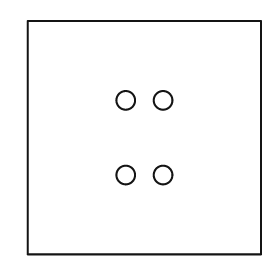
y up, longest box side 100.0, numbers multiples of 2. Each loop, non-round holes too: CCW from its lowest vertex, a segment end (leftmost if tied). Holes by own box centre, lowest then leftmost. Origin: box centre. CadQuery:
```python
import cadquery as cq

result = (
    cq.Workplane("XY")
    .moveTo(-50.0, -50.0)
    .lineTo(50.0, -50.0)
    .lineTo(50.0, 50.0)
    .lineTo(-50.0, 50.0)
    .close()
    .moveTo(-8.0, -16.0)
    .circle(4.0)
    .moveTo(8.0, -16.0)
    .circle(4.0)
    .moveTo(-8.0, 16.0)
    .circle(4.0)
    .moveTo(8.0, 16.0)
    .circle(4.0)
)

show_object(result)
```